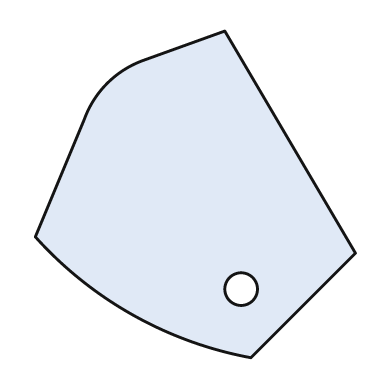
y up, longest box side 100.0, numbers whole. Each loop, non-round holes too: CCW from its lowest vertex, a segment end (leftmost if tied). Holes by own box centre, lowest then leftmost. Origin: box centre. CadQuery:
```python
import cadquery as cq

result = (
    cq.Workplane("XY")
    .moveTo(17.0, -50.0)
    .lineTo(49.0, -18.0)
    .lineTo(9.0, 50.0)
    .lineTo(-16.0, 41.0)
    .threePointArc((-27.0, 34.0), (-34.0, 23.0))
    .lineTo(-49.0, -13.0)
    .threePointArc((-19.0, -37.0), (17.0, -50.0))
    .close()
    .moveTo(14.0, -29.0)
    .circle(5.0)
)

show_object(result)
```